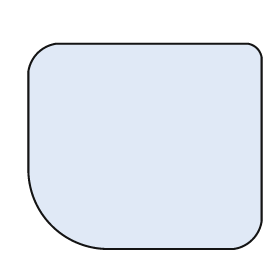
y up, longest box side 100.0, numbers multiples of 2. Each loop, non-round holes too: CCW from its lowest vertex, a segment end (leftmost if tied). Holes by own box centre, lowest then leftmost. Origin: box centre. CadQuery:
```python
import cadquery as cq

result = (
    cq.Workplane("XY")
    .moveTo(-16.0, -44.0)
    .lineTo(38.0, -44.0)
    .threePointArc((46.0, -40.0), (50.0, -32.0))
    .lineTo(50.0, 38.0)
    .threePointArc((48.0, 42.0), (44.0, 44.0))
    .lineTo(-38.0, 44.0)
    .threePointArc((-46.0, 40.0), (-50.0, 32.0))
    .lineTo(-50.0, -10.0)
    .threePointArc((-40.0, -34.0), (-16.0, -44.0))
    .close()
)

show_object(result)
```